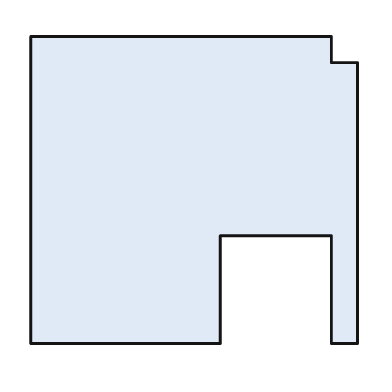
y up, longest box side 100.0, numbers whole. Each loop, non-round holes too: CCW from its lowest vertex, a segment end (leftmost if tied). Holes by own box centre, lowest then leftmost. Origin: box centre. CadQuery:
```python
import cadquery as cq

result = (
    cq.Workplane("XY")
    .moveTo(-50.0, -47.0)
    .lineTo(8.0, -47.0)
    .lineTo(8.0, -14.0)
    .lineTo(42.0, -14.0)
    .lineTo(42.0, -47.0)
    .lineTo(50.0, -47.0)
    .lineTo(50.0, 39.0)
    .lineTo(42.0, 39.0)
    .lineTo(42.0, 47.0)
    .lineTo(-50.0, 47.0)
    .close()
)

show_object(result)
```